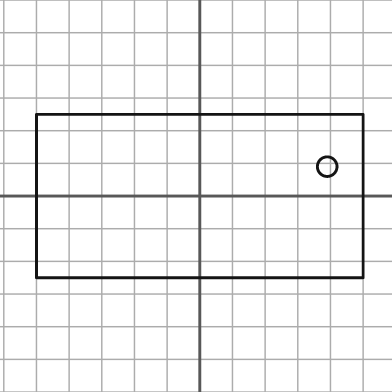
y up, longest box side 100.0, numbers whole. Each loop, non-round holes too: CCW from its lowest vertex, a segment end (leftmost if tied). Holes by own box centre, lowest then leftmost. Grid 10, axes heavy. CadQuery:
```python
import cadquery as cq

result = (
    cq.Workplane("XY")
    .moveTo(-50.0, -25.0)
    .lineTo(50.0, -25.0)
    .lineTo(50.0, 25.0)
    .lineTo(-50.0, 25.0)
    .close()
    .moveTo(39.0, 9.0)
    .circle(3.0)
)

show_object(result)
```